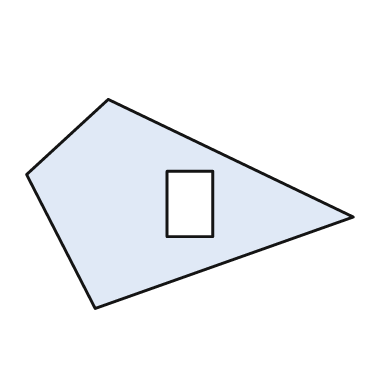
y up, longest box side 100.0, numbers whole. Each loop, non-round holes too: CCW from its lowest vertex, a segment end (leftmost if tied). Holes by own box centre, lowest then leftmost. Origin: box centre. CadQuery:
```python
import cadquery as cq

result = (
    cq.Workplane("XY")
    .moveTo(-29.0, -32.0)
    .lineTo(50.0, -4.0)
    .lineTo(-25.0, 32.0)
    .lineTo(-50.0, 9.0)
    .close()
    .moveTo(-7.0, -10.0)
    .lineTo(7.0, -10.0)
    .lineTo(7.0, 10.0)
    .lineTo(-7.0, 10.0)
    .close()
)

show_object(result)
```